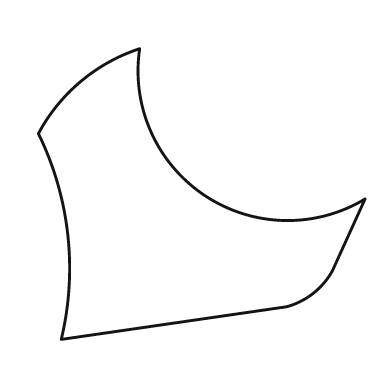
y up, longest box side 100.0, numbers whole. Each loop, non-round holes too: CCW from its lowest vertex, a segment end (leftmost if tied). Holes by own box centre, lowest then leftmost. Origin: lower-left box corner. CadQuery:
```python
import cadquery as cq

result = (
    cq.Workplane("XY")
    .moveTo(7.0, 0.0)
    .lineTo(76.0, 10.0)
    .threePointArc((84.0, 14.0), (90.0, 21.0))
    .lineTo(100.0, 43.0)
    .threePointArc((51.0, 44.0), (31.0, 89.0))
    .threePointArc((13.0, 79.0), (0.0, 63.0))
    .threePointArc((9.0, 32.0), (7.0, 0.0))
    .close()
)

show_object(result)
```